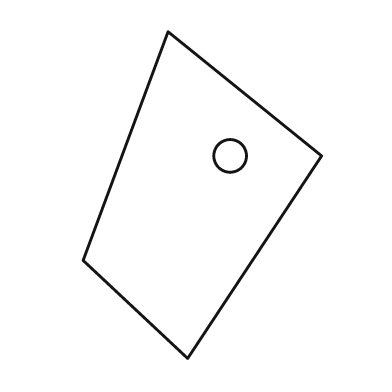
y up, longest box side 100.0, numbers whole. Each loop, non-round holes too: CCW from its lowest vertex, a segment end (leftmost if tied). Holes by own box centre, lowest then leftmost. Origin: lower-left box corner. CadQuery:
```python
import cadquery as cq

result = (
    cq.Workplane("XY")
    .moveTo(32.0, 0.0)
    .lineTo(73.0, 62.0)
    .lineTo(26.0, 100.0)
    .lineTo(0.0, 30.0)
    .close()
    .moveTo(45.0, 62.0)
    .circle(5.0)
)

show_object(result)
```